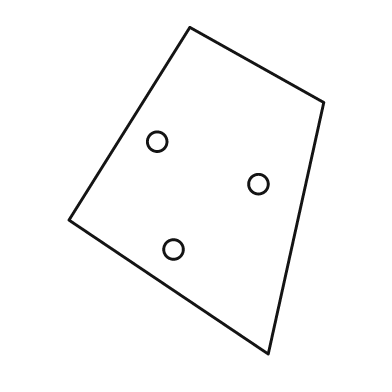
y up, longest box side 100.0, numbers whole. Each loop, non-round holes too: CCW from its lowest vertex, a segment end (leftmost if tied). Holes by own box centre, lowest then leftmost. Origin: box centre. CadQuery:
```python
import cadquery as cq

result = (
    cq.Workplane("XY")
    .moveTo(22.0, -50.0)
    .lineTo(39.0, 27.0)
    .lineTo(-2.0, 50.0)
    .lineTo(-39.0, -9.0)
    .close()
    .moveTo(-7.0, -18.0)
    .circle(3.0)
    .moveTo(19.0, 2.0)
    .circle(3.0)
    .moveTo(-12.0, 15.0)
    .circle(3.0)
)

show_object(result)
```